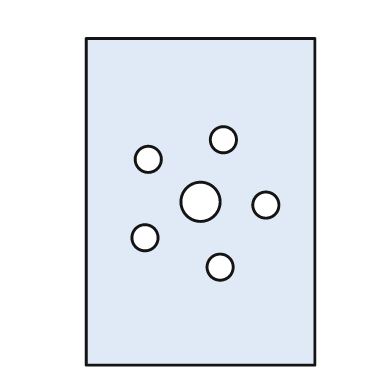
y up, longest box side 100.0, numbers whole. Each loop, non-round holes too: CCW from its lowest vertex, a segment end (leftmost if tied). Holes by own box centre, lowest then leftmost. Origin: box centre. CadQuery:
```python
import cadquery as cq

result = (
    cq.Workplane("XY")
    .moveTo(-35.0, -50.0)
    .lineTo(35.0, -50.0)
    .lineTo(35.0, 50.0)
    .lineTo(-35.0, 50.0)
    .close()
    .moveTo(6.0, -20.0)
    .circle(4.0)
    .moveTo(-17.0, -11.0)
    .circle(4.0)
    .moveTo(20.0, -1.0)
    .circle(4.0)
    .moveTo(0.0, 0.0)
    .circle(6.0)
    .moveTo(-16.0, 13.0)
    .circle(4.0)
    .moveTo(7.0, 19.0)
    .circle(4.0)
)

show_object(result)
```